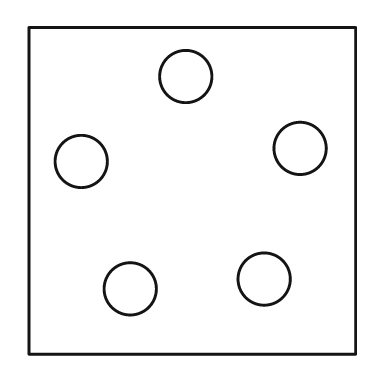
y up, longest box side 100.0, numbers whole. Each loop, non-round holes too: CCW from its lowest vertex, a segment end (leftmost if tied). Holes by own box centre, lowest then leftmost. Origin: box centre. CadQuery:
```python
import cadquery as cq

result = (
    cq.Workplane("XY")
    .moveTo(-50.0, -50.0)
    .lineTo(50.0, -50.0)
    .lineTo(50.0, 50.0)
    .lineTo(-50.0, 50.0)
    .close()
    .moveTo(-19.0, -30.0)
    .circle(8.0)
    .moveTo(22.0, -27.0)
    .circle(8.0)
    .moveTo(-34.0, 9.0)
    .circle(8.0)
    .moveTo(33.0, 13.0)
    .circle(8.0)
    .moveTo(-2.0, 35.0)
    .circle(8.0)
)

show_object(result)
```